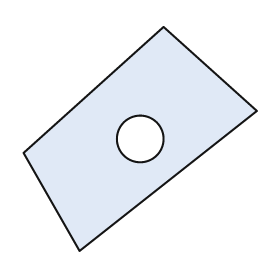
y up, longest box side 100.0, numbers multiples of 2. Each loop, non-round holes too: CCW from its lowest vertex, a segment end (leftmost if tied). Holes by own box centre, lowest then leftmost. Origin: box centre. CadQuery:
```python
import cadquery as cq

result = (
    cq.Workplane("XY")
    .moveTo(-26.0, -48.0)
    .lineTo(50.0, 12.0)
    .lineTo(10.0, 48.0)
    .lineTo(-50.0, -6.0)
    .close()
    .moveTo(0.0, 0.0)
    .circle(10.0)
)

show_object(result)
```